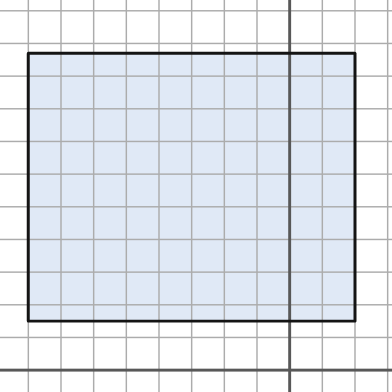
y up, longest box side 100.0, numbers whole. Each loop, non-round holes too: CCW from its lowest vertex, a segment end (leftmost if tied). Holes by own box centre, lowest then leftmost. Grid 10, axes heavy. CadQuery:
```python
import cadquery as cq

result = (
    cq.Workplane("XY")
    .moveTo(-80.0, 15.0)
    .lineTo(20.0, 15.0)
    .lineTo(20.0, 97.0)
    .lineTo(-80.0, 97.0)
    .close()
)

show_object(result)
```